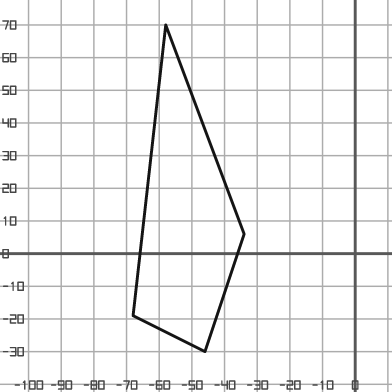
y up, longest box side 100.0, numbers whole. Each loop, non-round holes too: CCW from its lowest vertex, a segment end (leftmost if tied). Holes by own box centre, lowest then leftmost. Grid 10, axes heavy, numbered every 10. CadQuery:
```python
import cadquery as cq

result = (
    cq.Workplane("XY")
    .moveTo(-46.0, -30.0)
    .lineTo(-34.0, 6.0)
    .lineTo(-58.0, 70.0)
    .lineTo(-68.0, -19.0)
    .close()
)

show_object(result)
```